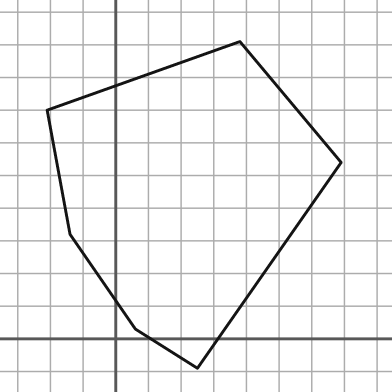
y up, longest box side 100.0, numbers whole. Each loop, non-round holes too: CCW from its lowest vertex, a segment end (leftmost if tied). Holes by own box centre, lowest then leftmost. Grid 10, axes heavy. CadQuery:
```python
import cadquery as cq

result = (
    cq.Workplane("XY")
    .moveTo(25.0, -9.0)
    .lineTo(69.0, 54.0)
    .lineTo(38.0, 91.0)
    .lineTo(-21.0, 70.0)
    .lineTo(-14.0, 32.0)
    .lineTo(6.0, 3.0)
    .close()
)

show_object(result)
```